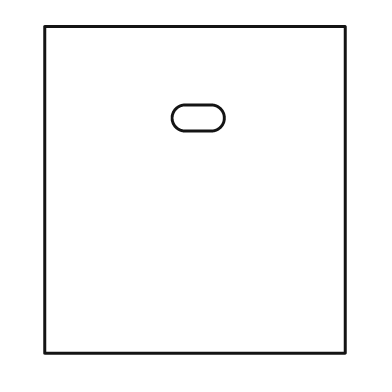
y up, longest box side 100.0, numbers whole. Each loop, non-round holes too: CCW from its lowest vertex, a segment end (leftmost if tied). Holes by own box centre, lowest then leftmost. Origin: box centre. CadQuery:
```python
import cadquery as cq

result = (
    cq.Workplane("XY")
    .moveTo(-46.0, -50.0)
    .lineTo(46.0, -50.0)
    .lineTo(46.0, 50.0)
    .lineTo(-46.0, 50.0)
    .close()
    .moveTo(-3.0, 18.0)
    .lineTo(5.0, 18.0)
    .threePointArc((9.0, 22.0), (5.0, 26.0))
    .lineTo(-3.0, 26.0)
    .threePointArc((-7.0, 22.0), (-3.0, 18.0))
    .close()
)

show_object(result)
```